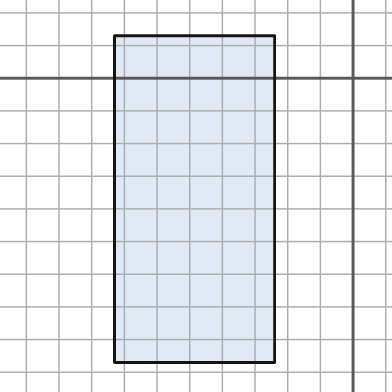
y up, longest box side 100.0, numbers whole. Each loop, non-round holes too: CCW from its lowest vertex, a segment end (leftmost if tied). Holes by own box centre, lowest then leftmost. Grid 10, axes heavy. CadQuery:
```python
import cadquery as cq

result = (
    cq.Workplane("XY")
    .moveTo(-73.0, -87.0)
    .lineTo(-24.0, -87.0)
    .lineTo(-24.0, 13.0)
    .lineTo(-73.0, 13.0)
    .close()
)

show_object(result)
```